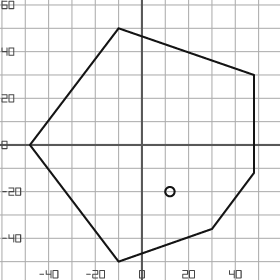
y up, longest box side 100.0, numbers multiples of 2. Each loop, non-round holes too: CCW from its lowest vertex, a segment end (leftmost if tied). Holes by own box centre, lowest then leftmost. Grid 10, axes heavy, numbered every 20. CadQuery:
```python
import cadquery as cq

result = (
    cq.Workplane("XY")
    .moveTo(-10.0, -50.0)
    .lineTo(30.0, -36.0)
    .lineTo(48.0, -12.0)
    .lineTo(48.0, 30.0)
    .lineTo(-10.0, 50.0)
    .lineTo(-48.0, 0.0)
    .close()
    .moveTo(12.0, -20.0)
    .circle(2.0)
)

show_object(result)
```